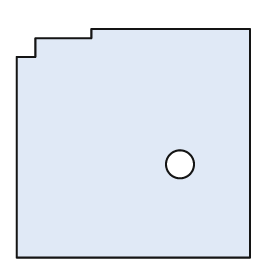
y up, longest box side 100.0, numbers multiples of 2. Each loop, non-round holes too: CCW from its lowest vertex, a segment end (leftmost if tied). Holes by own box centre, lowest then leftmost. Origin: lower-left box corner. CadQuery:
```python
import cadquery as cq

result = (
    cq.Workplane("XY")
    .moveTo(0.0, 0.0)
    .lineTo(100.0, 0.0)
    .lineTo(100.0, 98.0)
    .lineTo(32.0, 98.0)
    .lineTo(32.0, 94.0)
    .lineTo(8.0, 94.0)
    .lineTo(8.0, 86.0)
    .lineTo(0.0, 86.0)
    .close()
    .moveTo(70.0, 40.0)
    .circle(6.0)
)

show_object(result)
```